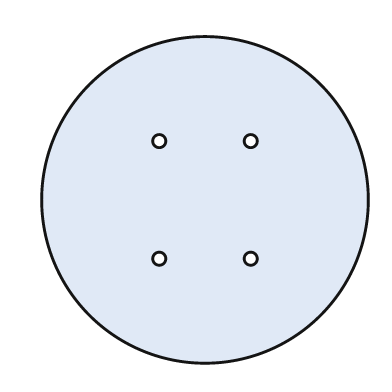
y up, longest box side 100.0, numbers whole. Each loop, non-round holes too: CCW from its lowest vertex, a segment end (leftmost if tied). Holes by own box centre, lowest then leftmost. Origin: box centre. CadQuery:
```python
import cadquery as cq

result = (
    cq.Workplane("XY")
    .moveTo(0.0, 0.0)
    .circle(50.0)
    .moveTo(-14.0, -18.0)
    .circle(2.0)
    .moveTo(14.0, -18.0)
    .circle(2.0)
    .moveTo(-14.0, 18.0)
    .circle(2.0)
    .moveTo(14.0, 18.0)
    .circle(2.0)
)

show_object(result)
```